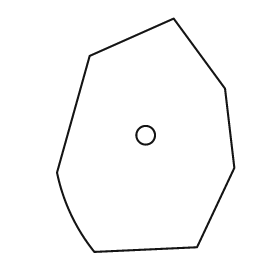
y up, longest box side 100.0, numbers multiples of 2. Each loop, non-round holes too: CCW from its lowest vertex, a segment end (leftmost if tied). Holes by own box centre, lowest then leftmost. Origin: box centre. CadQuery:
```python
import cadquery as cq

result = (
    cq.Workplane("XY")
    .moveTo(-22.0, -50.0)
    .lineTo(22.0, -48.0)
    .lineTo(38.0, -14.0)
    .lineTo(34.0, 20.0)
    .lineTo(12.0, 50.0)
    .lineTo(-24.0, 34.0)
    .lineTo(-38.0, -16.0)
    .threePointArc((-32.0, -34.0), (-22.0, -50.0))
    .close()
    .moveTo(0.0, 0.0)
    .circle(4.0)
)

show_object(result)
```